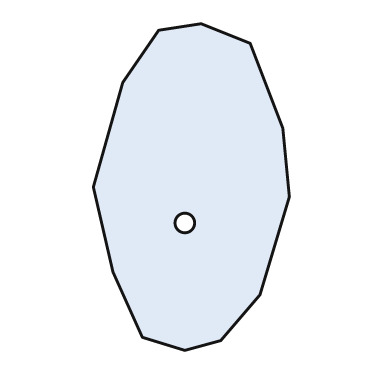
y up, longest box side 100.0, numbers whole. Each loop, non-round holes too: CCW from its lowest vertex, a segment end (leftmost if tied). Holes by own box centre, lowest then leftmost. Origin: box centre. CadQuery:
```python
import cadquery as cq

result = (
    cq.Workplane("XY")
    .moveTo(-2.0, -50.0)
    .lineTo(9.0, -47.0)
    .lineTo(21.0, -33.0)
    .lineTo(30.0, -3.0)
    .lineTo(28.0, 18.0)
    .lineTo(18.0, 44.0)
    .lineTo(3.0, 50.0)
    .lineTo(-10.0, 48.0)
    .lineTo(-21.0, 32.0)
    .lineTo(-30.0, 0.0)
    .lineTo(-24.0, -26.0)
    .lineTo(-15.0, -46.0)
    .close()
    .moveTo(-2.0, -11.0)
    .circle(3.0)
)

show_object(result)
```